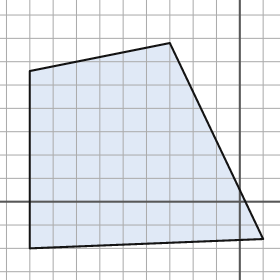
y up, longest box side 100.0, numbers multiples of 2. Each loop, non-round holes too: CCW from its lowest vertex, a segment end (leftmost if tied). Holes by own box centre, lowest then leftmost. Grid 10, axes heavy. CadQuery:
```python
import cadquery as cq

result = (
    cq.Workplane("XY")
    .moveTo(-90.0, -20.0)
    .lineTo(10.0, -16.0)
    .lineTo(-30.0, 68.0)
    .lineTo(-90.0, 56.0)
    .close()
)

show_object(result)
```